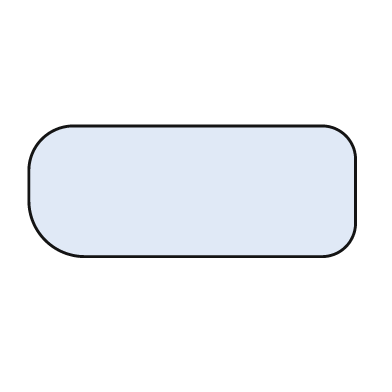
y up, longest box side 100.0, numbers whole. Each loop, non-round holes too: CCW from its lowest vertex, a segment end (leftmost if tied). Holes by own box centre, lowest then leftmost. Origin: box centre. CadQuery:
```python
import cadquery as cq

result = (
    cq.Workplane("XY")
    .moveTo(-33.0, -20.0)
    .lineTo(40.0, -20.0)
    .threePointArc((47.0, -17.0), (50.0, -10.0))
    .lineTo(50.0, 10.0)
    .threePointArc((47.0, 17.0), (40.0, 20.0))
    .lineTo(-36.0, 20.0)
    .threePointArc((-46.0, 16.0), (-50.0, 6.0))
    .lineTo(-50.0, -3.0)
    .threePointArc((-45.0, -15.0), (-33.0, -20.0))
    .close()
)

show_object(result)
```